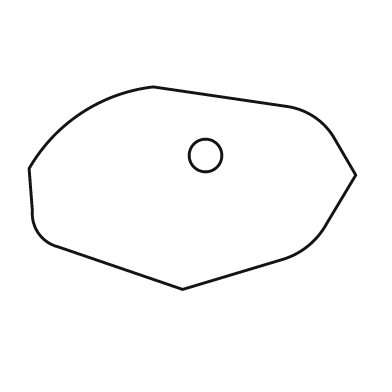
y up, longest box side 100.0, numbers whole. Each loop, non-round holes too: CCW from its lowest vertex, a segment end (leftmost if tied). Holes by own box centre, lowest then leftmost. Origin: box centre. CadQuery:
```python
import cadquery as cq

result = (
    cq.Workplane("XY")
    .moveTo(-3.0, -31.0)
    .lineTo(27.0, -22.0)
    .threePointArc((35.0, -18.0), (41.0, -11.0))
    .lineTo(50.0, 4.0)
    .lineTo(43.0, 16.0)
    .threePointArc((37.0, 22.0), (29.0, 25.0))
    .lineTo(-12.0, 31.0)
    .threePointArc((-34.0, 23.0), (-50.0, 6.0))
    .lineTo(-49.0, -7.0)
    .threePointArc((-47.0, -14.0), (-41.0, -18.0))
    .close()
    .moveTo(4.0, 10.0)
    .circle(5.0)
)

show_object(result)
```